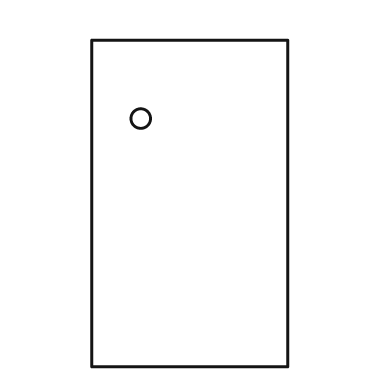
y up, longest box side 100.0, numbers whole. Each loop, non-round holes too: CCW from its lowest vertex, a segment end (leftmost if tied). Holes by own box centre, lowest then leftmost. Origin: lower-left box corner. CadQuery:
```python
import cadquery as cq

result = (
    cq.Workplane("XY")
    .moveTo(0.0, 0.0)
    .lineTo(60.0, 0.0)
    .lineTo(60.0, 100.0)
    .lineTo(0.0, 100.0)
    .close()
    .moveTo(15.0, 76.0)
    .circle(3.0)
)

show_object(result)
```